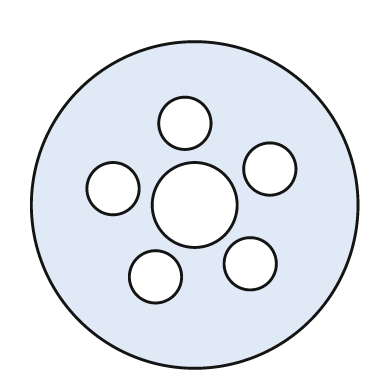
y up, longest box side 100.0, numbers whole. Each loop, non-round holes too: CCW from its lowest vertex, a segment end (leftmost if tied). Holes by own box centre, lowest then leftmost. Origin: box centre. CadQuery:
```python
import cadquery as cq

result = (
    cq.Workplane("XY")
    .moveTo(0.0, 0.0)
    .circle(50.0)
    .moveTo(-12.0, -22.0)
    .circle(8.0)
    .moveTo(17.0, -18.0)
    .circle(8.0)
    .moveTo(0.0, 0.0)
    .circle(13.0)
    .moveTo(-25.0, 5.0)
    .circle(8.0)
    .moveTo(23.0, 11.0)
    .circle(8.0)
    .moveTo(-3.0, 25.0)
    .circle(8.0)
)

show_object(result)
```